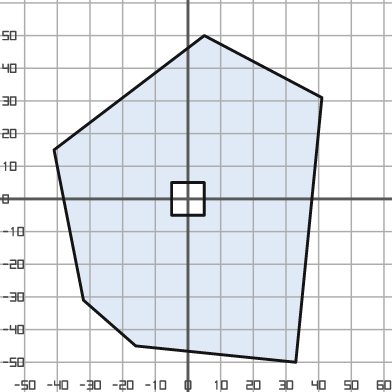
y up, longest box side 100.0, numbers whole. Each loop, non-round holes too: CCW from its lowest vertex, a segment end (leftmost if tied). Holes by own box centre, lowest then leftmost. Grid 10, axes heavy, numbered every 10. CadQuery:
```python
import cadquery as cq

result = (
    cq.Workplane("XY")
    .moveTo(33.0, -50.0)
    .lineTo(41.0, 31.0)
    .lineTo(5.0, 50.0)
    .lineTo(-41.0, 15.0)
    .lineTo(-32.0, -31.0)
    .lineTo(-16.0, -45.0)
    .close()
    .moveTo(-5.0, -5.0)
    .lineTo(5.0, -5.0)
    .lineTo(5.0, 5.0)
    .lineTo(-5.0, 5.0)
    .close()
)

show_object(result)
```